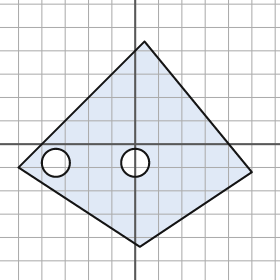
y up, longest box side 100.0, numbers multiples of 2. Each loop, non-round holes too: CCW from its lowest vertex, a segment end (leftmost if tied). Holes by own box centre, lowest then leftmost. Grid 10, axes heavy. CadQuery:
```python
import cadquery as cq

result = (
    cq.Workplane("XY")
    .moveTo(2.0, -44.0)
    .lineTo(50.0, -12.0)
    .lineTo(4.0, 44.0)
    .lineTo(-50.0, -10.0)
    .close()
    .moveTo(-34.0, -8.0)
    .circle(6.0)
    .moveTo(0.0, -8.0)
    .circle(6.0)
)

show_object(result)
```